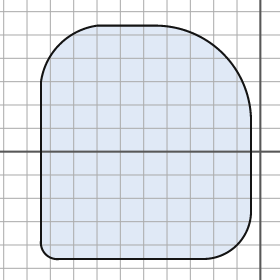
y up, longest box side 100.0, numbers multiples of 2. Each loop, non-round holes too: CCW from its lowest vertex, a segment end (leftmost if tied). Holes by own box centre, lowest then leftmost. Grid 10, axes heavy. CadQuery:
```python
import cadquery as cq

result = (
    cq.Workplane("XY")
    .moveTo(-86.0, -46.0)
    .lineTo(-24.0, -46.0)
    .threePointArc((-10.0, -40.0), (-4.0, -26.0))
    .lineTo(-4.0, 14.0)
    .threePointArc((-16.0, 42.0), (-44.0, 54.0))
    .lineTo(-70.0, 54.0)
    .threePointArc((-86.0, 46.0), (-94.0, 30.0))
    .lineTo(-94.0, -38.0)
    .threePointArc((-92.0, -44.0), (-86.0, -46.0))
    .close()
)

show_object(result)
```